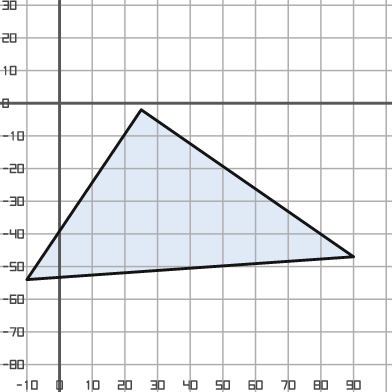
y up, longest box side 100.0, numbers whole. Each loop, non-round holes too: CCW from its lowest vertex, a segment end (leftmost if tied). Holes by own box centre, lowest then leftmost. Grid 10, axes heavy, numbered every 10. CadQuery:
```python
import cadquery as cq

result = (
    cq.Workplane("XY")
    .moveTo(-10.0, -54.0)
    .lineTo(90.0, -47.0)
    .lineTo(25.0, -2.0)
    .close()
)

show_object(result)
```